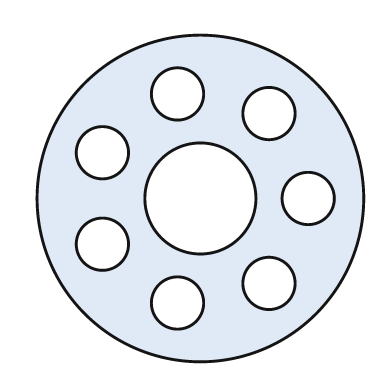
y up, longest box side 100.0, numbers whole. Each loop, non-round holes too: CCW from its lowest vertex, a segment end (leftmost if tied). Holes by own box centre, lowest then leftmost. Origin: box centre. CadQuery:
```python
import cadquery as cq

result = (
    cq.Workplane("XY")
    .moveTo(0.0, 0.0)
    .circle(50.0)
    .moveTo(-7.0, -32.0)
    .circle(8.0)
    .moveTo(21.0, -26.0)
    .circle(8.0)
    .moveTo(-30.0, -14.0)
    .circle(8.0)
    .moveTo(0.0, 0.0)
    .circle(17.0)
    .moveTo(33.0, 0.0)
    .circle(8.0)
    .moveTo(-30.0, 14.0)
    .circle(8.0)
    .moveTo(21.0, 26.0)
    .circle(8.0)
    .moveTo(-7.0, 32.0)
    .circle(8.0)
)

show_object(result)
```